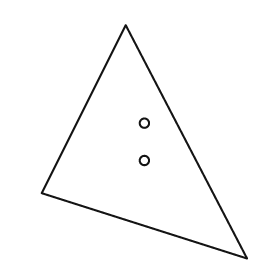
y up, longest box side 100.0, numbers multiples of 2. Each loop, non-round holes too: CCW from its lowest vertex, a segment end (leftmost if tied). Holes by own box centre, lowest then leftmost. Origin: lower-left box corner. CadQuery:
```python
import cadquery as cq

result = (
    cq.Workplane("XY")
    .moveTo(88.0, 0.0)
    .lineTo(36.0, 100.0)
    .lineTo(0.0, 28.0)
    .close()
    .moveTo(44.0, 42.0)
    .circle(2.0)
    .moveTo(44.0, 58.0)
    .circle(2.0)
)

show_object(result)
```